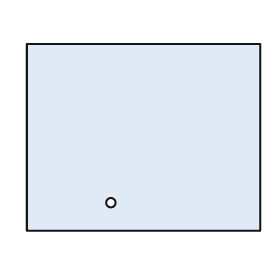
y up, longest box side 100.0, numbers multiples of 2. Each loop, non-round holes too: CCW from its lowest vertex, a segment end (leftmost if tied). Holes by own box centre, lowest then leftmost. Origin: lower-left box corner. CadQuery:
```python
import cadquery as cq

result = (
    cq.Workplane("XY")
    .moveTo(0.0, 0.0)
    .lineTo(100.0, 0.0)
    .lineTo(100.0, 80.0)
    .lineTo(0.0, 80.0)
    .close()
    .moveTo(36.0, 12.0)
    .circle(2.0)
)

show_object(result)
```